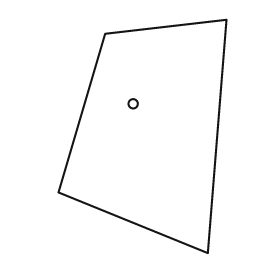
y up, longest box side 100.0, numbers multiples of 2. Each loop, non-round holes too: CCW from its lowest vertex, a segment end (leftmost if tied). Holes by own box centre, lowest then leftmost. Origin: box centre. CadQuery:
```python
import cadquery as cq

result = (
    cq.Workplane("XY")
    .moveTo(28.0, -50.0)
    .lineTo(36.0, 50.0)
    .lineTo(-16.0, 44.0)
    .lineTo(-36.0, -24.0)
    .close()
    .moveTo(-4.0, 14.0)
    .circle(2.0)
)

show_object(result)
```